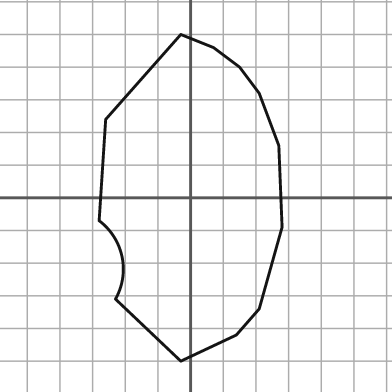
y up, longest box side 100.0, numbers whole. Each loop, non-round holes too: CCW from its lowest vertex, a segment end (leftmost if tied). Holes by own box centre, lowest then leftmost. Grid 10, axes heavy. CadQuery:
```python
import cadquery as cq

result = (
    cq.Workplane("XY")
    .moveTo(-3.0, -50.0)
    .lineTo(14.0, -42.0)
    .lineTo(21.0, -34.0)
    .lineTo(28.0, -9.0)
    .lineTo(27.0, 16.0)
    .lineTo(21.0, 32.0)
    .lineTo(15.0, 40.0)
    .lineTo(7.0, 46.0)
    .lineTo(-3.0, 50.0)
    .lineTo(-26.0, 24.0)
    .lineTo(-28.0, -7.0)
    .threePointArc((-21.0, -18.0), (-23.0, -31.0))
    .close()
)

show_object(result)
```